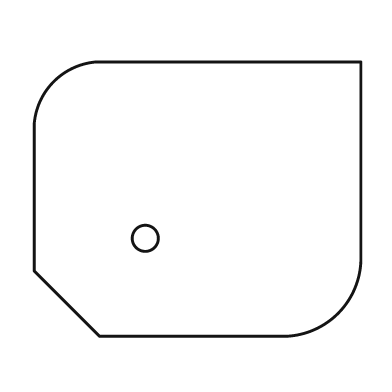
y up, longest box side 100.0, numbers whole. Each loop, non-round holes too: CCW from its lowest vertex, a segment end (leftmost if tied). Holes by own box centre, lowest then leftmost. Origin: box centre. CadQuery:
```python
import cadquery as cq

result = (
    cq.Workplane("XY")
    .moveTo(-30.0, -42.0)
    .lineTo(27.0, -42.0)
    .threePointArc((43.0, -35.0), (50.0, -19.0))
    .lineTo(50.0, 42.0)
    .lineTo(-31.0, 42.0)
    .threePointArc((-44.0, 36.0), (-50.0, 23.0))
    .lineTo(-50.0, -22.0)
    .close()
    .moveTo(-16.0, -12.0)
    .circle(4.0)
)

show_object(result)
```